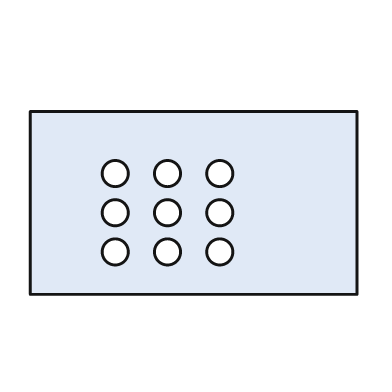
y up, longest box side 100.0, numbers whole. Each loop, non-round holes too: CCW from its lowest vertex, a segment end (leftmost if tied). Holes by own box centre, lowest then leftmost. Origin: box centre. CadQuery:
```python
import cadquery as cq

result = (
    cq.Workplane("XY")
    .moveTo(-50.0, -28.0)
    .lineTo(50.0, -28.0)
    .lineTo(50.0, 28.0)
    .lineTo(-50.0, 28.0)
    .close()
    .moveTo(-24.0, -15.0)
    .circle(4.0)
    .moveTo(-8.0, -15.0)
    .circle(4.0)
    .moveTo(8.0, -15.0)
    .circle(4.0)
    .moveTo(-24.0, -3.0)
    .circle(4.0)
    .moveTo(-8.0, -3.0)
    .circle(4.0)
    .moveTo(8.0, -3.0)
    .circle(4.0)
    .moveTo(-24.0, 9.0)
    .circle(4.0)
    .moveTo(-8.0, 9.0)
    .circle(4.0)
    .moveTo(8.0, 9.0)
    .circle(4.0)
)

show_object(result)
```